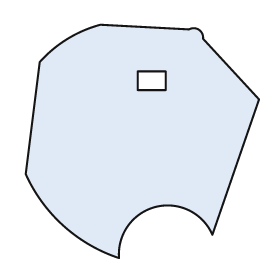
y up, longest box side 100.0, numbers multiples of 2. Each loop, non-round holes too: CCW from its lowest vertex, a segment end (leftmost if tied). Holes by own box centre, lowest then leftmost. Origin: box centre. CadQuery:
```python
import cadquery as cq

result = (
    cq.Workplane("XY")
    .moveTo(-10.0, -50.0)
    .threePointArc((6.0, -28.0), (30.0, -40.0))
    .lineTo(50.0, 18.0)
    .lineTo(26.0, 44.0)
    .threePointArc((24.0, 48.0), (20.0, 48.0))
    .lineTo(-18.0, 50.0)
    .threePointArc((-32.0, 44.0), (-44.0, 34.0))
    .lineTo(-50.0, -14.0)
    .threePointArc((-34.0, -36.0), (-10.0, -50.0))
    .close()
    .moveTo(-2.0, 22.0)
    .lineTo(10.0, 22.0)
    .lineTo(10.0, 30.0)
    .lineTo(-2.0, 30.0)
    .close()
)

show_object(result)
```